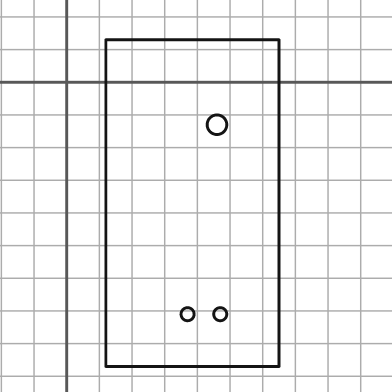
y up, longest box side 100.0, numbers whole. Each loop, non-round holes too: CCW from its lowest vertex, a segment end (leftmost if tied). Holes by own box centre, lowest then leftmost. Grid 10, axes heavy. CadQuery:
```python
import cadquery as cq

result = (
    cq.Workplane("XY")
    .moveTo(12.0, -87.0)
    .lineTo(65.0, -87.0)
    .lineTo(65.0, 13.0)
    .lineTo(12.0, 13.0)
    .close()
    .moveTo(37.0, -71.0)
    .circle(2.0)
    .moveTo(47.0, -71.0)
    .circle(2.0)
    .moveTo(46.0, -13.0)
    .circle(3.0)
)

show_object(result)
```